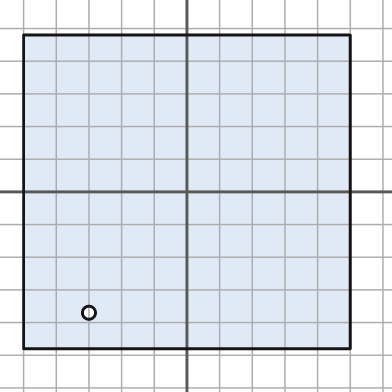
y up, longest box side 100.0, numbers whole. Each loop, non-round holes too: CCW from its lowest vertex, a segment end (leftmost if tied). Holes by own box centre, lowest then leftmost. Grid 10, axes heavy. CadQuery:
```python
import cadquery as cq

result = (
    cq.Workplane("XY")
    .moveTo(-50.0, -48.0)
    .lineTo(50.0, -48.0)
    .lineTo(50.0, 48.0)
    .lineTo(-50.0, 48.0)
    .close()
    .moveTo(-30.0, -37.0)
    .circle(2.0)
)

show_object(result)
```